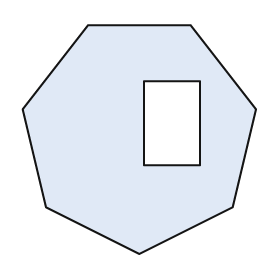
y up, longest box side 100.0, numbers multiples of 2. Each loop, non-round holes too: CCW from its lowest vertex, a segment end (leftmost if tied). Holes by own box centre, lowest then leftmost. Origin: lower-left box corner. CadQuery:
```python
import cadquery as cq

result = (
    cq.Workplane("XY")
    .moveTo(50.0, 0.0)
    .lineTo(90.0, 20.0)
    .lineTo(100.0, 62.0)
    .lineTo(72.0, 98.0)
    .lineTo(28.0, 98.0)
    .lineTo(0.0, 62.0)
    .lineTo(10.0, 20.0)
    .close()
    .moveTo(52.0, 38.0)
    .lineTo(76.0, 38.0)
    .lineTo(76.0, 74.0)
    .lineTo(52.0, 74.0)
    .close()
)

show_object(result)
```